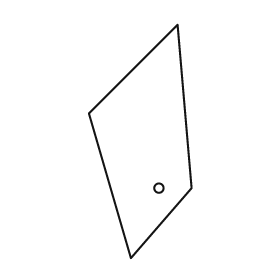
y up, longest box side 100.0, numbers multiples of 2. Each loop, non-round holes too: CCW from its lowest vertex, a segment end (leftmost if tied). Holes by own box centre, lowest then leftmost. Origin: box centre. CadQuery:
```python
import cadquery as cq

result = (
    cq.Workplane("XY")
    .moveTo(-4.0, -50.0)
    .lineTo(22.0, -20.0)
    .lineTo(16.0, 50.0)
    .lineTo(-22.0, 12.0)
    .close()
    .moveTo(8.0, -20.0)
    .circle(2.0)
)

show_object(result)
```